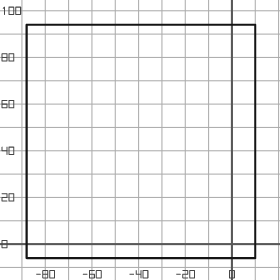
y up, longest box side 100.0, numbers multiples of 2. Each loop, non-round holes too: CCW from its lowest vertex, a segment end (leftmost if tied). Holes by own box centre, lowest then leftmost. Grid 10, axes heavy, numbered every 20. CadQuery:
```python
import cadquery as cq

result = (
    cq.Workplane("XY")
    .moveTo(-88.0, -6.0)
    .lineTo(10.0, -6.0)
    .lineTo(10.0, 94.0)
    .lineTo(-88.0, 94.0)
    .close()
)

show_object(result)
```